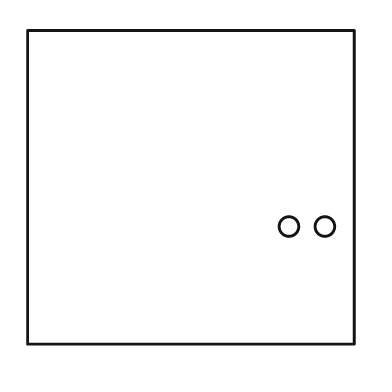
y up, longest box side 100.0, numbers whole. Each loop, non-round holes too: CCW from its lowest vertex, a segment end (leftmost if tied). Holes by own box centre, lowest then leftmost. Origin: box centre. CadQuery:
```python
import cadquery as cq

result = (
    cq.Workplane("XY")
    .moveTo(-50.0, -48.0)
    .lineTo(50.0, -48.0)
    .lineTo(50.0, 48.0)
    .lineTo(-50.0, 48.0)
    .close()
    .moveTo(30.0, -12.0)
    .circle(3.0)
    .moveTo(41.0, -12.0)
    .circle(3.0)
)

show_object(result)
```